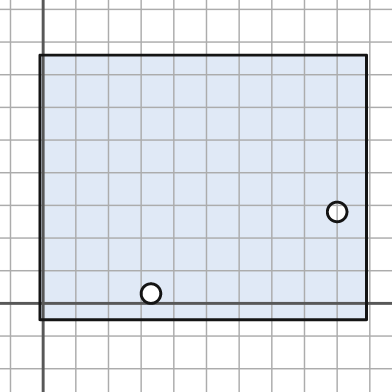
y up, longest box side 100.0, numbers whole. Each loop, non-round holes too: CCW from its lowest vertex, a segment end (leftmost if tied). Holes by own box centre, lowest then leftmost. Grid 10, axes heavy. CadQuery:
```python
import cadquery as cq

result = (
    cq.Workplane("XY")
    .moveTo(-1.0, -5.0)
    .lineTo(99.0, -5.0)
    .lineTo(99.0, 76.0)
    .lineTo(-1.0, 76.0)
    .close()
    .moveTo(33.0, 3.0)
    .circle(3.0)
    .moveTo(90.0, 28.0)
    .circle(3.0)
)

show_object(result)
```